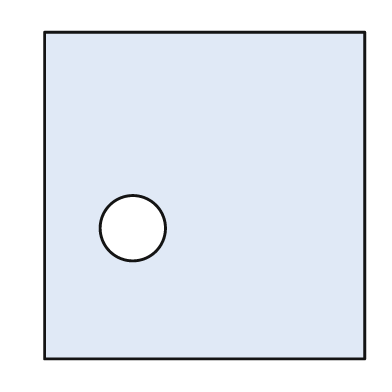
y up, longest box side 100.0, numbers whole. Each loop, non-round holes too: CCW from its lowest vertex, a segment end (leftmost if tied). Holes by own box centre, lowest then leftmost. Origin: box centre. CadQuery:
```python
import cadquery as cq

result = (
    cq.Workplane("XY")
    .moveTo(-49.0, -50.0)
    .lineTo(49.0, -50.0)
    .lineTo(49.0, 50.0)
    .lineTo(-49.0, 50.0)
    .close()
    .moveTo(-22.0, -10.0)
    .circle(10.0)
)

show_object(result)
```